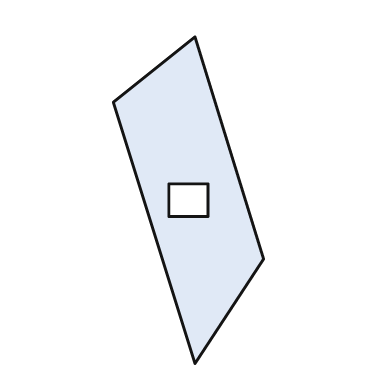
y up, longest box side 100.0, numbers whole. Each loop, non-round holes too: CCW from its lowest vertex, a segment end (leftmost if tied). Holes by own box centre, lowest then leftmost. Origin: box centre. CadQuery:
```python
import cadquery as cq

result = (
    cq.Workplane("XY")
    .moveTo(2.0, -50.0)
    .lineTo(23.0, -18.0)
    .lineTo(2.0, 50.0)
    .lineTo(-23.0, 30.0)
    .close()
    .moveTo(-6.0, -5.0)
    .lineTo(6.0, -5.0)
    .lineTo(6.0, 5.0)
    .lineTo(-6.0, 5.0)
    .close()
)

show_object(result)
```